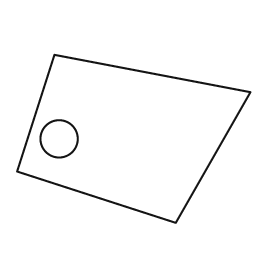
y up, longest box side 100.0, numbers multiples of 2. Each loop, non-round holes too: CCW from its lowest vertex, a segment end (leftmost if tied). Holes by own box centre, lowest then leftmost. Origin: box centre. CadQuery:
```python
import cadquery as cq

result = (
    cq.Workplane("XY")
    .moveTo(18.0, -36.0)
    .lineTo(50.0, 20.0)
    .lineTo(-34.0, 36.0)
    .lineTo(-50.0, -14.0)
    .close()
    .moveTo(-32.0, 0.0)
    .circle(8.0)
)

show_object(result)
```